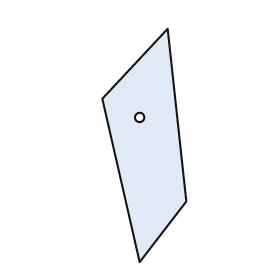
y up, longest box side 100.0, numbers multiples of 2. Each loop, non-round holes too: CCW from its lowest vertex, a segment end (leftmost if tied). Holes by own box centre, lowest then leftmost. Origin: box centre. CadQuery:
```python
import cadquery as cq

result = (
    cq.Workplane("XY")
    .moveTo(-2.0, -50.0)
    .lineTo(18.0, -24.0)
    .lineTo(10.0, 50.0)
    .lineTo(-18.0, 20.0)
    .close()
    .moveTo(-2.0, 12.0)
    .circle(2.0)
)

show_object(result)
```